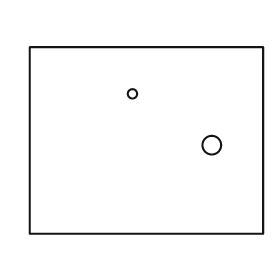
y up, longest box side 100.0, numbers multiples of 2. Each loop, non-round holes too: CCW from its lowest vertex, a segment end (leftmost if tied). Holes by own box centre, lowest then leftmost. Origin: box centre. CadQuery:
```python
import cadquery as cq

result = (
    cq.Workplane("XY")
    .moveTo(-50.0, -40.0)
    .lineTo(50.0, -40.0)
    .lineTo(50.0, 40.0)
    .lineTo(-50.0, 40.0)
    .close()
    .moveTo(28.0, -2.0)
    .circle(4.0)
    .moveTo(-6.0, 20.0)
    .circle(2.0)
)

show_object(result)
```